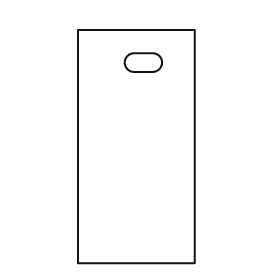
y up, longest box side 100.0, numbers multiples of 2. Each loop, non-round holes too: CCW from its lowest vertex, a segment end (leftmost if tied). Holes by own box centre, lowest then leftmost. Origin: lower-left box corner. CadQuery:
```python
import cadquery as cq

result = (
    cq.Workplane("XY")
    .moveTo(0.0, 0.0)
    .lineTo(50.0, 0.0)
    .lineTo(50.0, 100.0)
    .lineTo(0.0, 100.0)
    .close()
    .moveTo(24.0, 82.0)
    .lineTo(32.0, 82.0)
    .threePointArc((36.0, 86.0), (32.0, 90.0))
    .lineTo(24.0, 90.0)
    .threePointArc((20.0, 86.0), (24.0, 82.0))
    .close()
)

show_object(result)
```